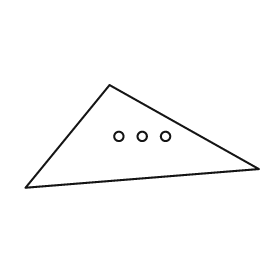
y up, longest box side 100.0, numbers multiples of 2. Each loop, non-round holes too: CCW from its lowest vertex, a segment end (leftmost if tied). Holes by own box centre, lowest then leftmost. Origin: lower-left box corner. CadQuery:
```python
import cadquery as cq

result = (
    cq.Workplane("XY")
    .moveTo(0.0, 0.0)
    .lineTo(100.0, 8.0)
    .lineTo(36.0, 44.0)
    .close()
    .moveTo(40.0, 22.0)
    .circle(2.0)
    .moveTo(50.0, 22.0)
    .circle(2.0)
    .moveTo(60.0, 22.0)
    .circle(2.0)
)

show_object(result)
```